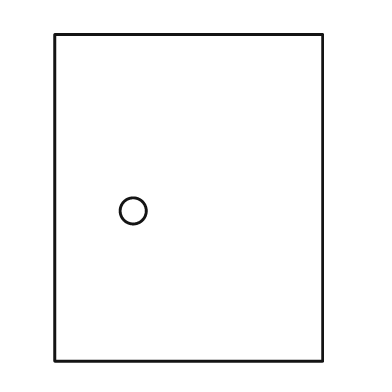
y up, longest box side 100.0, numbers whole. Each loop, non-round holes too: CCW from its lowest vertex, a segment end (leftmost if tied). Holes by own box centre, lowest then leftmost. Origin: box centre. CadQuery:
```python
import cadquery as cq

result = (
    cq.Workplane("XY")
    .moveTo(-41.0, -50.0)
    .lineTo(41.0, -50.0)
    .lineTo(41.0, 50.0)
    .lineTo(-41.0, 50.0)
    .close()
    .moveTo(-17.0, -4.0)
    .circle(4.0)
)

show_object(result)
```